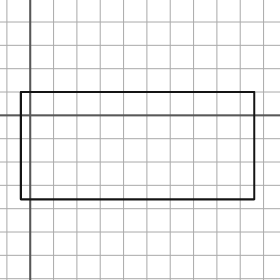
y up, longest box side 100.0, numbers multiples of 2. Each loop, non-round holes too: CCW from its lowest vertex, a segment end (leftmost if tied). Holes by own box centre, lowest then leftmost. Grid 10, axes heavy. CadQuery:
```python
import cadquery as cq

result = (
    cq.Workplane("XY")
    .moveTo(-4.0, -36.0)
    .lineTo(96.0, -36.0)
    .lineTo(96.0, 10.0)
    .lineTo(-4.0, 10.0)
    .close()
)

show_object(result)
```